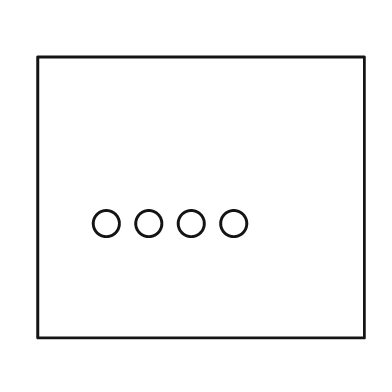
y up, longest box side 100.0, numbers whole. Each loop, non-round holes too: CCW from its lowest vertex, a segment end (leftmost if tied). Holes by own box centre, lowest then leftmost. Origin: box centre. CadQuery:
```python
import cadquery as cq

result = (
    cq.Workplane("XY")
    .moveTo(-50.0, -43.0)
    .lineTo(50.0, -43.0)
    .lineTo(50.0, 43.0)
    .lineTo(-50.0, 43.0)
    .close()
    .moveTo(-29.0, -8.0)
    .circle(4.0)
    .moveTo(-16.0, -8.0)
    .circle(4.0)
    .moveTo(-3.0, -8.0)
    .circle(4.0)
    .moveTo(10.0, -8.0)
    .circle(4.0)
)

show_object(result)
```